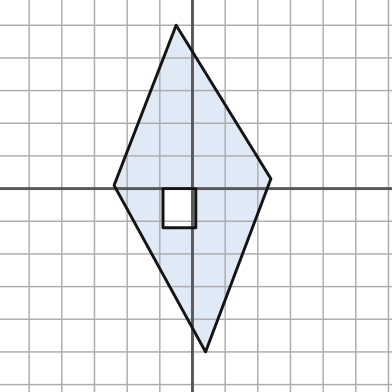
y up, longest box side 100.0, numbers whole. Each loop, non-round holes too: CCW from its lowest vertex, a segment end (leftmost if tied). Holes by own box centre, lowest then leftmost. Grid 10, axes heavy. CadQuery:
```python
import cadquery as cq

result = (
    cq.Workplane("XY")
    .moveTo(4.0, -50.0)
    .lineTo(24.0, 3.0)
    .lineTo(-5.0, 50.0)
    .lineTo(-24.0, 1.0)
    .close()
    .moveTo(-9.0, -12.0)
    .lineTo(1.0, -12.0)
    .lineTo(1.0, 0.0)
    .lineTo(-9.0, 0.0)
    .close()
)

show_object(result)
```